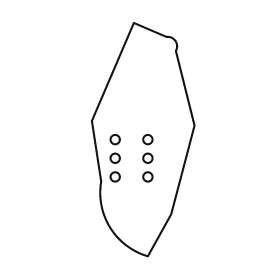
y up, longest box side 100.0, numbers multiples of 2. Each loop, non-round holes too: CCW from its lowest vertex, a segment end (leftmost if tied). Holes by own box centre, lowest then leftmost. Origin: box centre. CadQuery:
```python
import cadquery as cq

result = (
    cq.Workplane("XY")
    .moveTo(2.0, -50.0)
    .lineTo(12.0, -32.0)
    .lineTo(22.0, 6.0)
    .lineTo(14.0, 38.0)
    .threePointArc((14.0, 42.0), (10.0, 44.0))
    .lineTo(-4.0, 50.0)
    .lineTo(-22.0, 8.0)
    .lineTo(-18.0, -18.0)
    .threePointArc((-14.0, -38.0), (2.0, -50.0))
    .close()
    .moveTo(-12.0, -16.0)
    .circle(2.0)
    .moveTo(2.0, -16.0)
    .circle(2.0)
    .moveTo(-12.0, -8.0)
    .circle(2.0)
    .moveTo(2.0, -8.0)
    .circle(2.0)
    .moveTo(-12.0, 0.0)
    .circle(2.0)
    .moveTo(2.0, 0.0)
    .circle(2.0)
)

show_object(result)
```